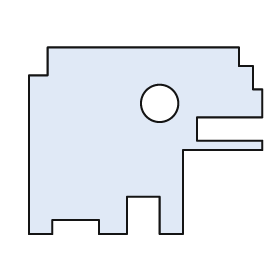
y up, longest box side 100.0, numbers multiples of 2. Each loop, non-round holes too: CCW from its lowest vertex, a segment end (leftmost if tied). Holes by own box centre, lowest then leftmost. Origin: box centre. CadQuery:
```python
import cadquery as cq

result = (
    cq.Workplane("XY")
    .moveTo(-50.0, -40.0)
    .lineTo(-40.0, -40.0)
    .lineTo(-40.0, -34.0)
    .lineTo(-20.0, -34.0)
    .lineTo(-20.0, -40.0)
    .lineTo(-8.0, -40.0)
    .lineTo(-8.0, -24.0)
    .lineTo(6.0, -24.0)
    .lineTo(6.0, -40.0)
    .lineTo(16.0, -40.0)
    .lineTo(16.0, -4.0)
    .lineTo(50.0, -4.0)
    .lineTo(50.0, 0.0)
    .lineTo(22.0, 0.0)
    .lineTo(22.0, 10.0)
    .lineTo(50.0, 10.0)
    .lineTo(50.0, 22.0)
    .lineTo(46.0, 22.0)
    .lineTo(46.0, 32.0)
    .lineTo(40.0, 32.0)
    .lineTo(40.0, 40.0)
    .lineTo(-42.0, 40.0)
    .lineTo(-42.0, 28.0)
    .lineTo(-50.0, 28.0)
    .close()
    .moveTo(6.0, 16.0)
    .circle(8.0)
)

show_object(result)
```